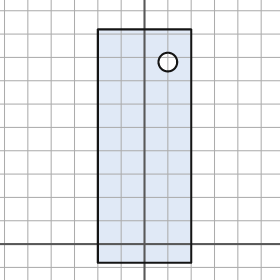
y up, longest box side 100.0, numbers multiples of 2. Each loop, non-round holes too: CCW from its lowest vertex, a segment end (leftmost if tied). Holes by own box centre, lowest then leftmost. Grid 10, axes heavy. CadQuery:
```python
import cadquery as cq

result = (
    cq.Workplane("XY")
    .moveTo(-20.0, -8.0)
    .lineTo(20.0, -8.0)
    .lineTo(20.0, 92.0)
    .lineTo(-20.0, 92.0)
    .close()
    .moveTo(10.0, 78.0)
    .circle(4.0)
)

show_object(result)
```